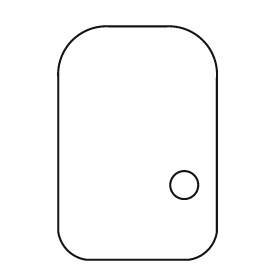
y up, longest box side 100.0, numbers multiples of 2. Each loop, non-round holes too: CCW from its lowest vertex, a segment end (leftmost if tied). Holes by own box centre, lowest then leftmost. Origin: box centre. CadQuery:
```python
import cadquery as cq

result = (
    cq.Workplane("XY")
    .moveTo(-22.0, -50.0)
    .lineTo(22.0, -50.0)
    .threePointArc((30.0, -46.0), (34.0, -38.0))
    .lineTo(34.0, 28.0)
    .threePointArc((28.0, 44.0), (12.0, 50.0))
    .lineTo(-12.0, 50.0)
    .threePointArc((-28.0, 44.0), (-34.0, 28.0))
    .lineTo(-34.0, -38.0)
    .threePointArc((-30.0, -46.0), (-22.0, -50.0))
    .close()
    .moveTo(20.0, -18.0)
    .circle(6.0)
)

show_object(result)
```